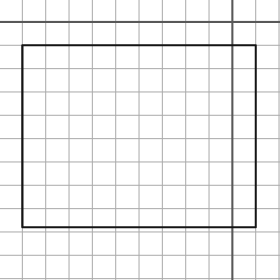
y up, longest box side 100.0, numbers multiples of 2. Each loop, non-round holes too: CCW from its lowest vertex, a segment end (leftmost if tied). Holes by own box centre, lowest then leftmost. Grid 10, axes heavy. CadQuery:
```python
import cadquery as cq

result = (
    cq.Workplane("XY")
    .moveTo(-90.0, -88.0)
    .lineTo(10.0, -88.0)
    .lineTo(10.0, -10.0)
    .lineTo(-90.0, -10.0)
    .close()
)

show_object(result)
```